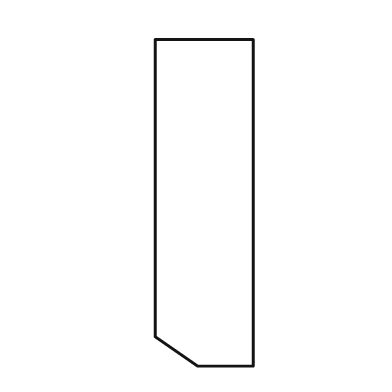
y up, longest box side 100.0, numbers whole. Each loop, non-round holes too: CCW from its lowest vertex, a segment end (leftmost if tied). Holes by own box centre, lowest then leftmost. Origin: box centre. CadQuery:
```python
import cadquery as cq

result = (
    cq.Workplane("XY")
    .moveTo(-2.0, -50.0)
    .lineTo(15.0, -50.0)
    .lineTo(15.0, 50.0)
    .lineTo(-15.0, 50.0)
    .lineTo(-15.0, -41.0)
    .close()
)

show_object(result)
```